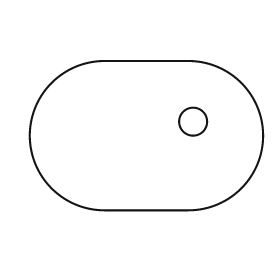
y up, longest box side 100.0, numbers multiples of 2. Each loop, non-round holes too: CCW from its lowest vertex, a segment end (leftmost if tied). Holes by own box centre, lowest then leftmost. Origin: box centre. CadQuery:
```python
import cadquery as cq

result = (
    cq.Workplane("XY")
    .moveTo(-18.0, -32.0)
    .lineTo(18.0, -32.0)
    .threePointArc((50.0, 0.0), (18.0, 32.0))
    .lineTo(-18.0, 32.0)
    .threePointArc((-50.0, 0.0), (-18.0, -32.0))
    .close()
    .moveTo(20.0, 6.0)
    .circle(6.0)
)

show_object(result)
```